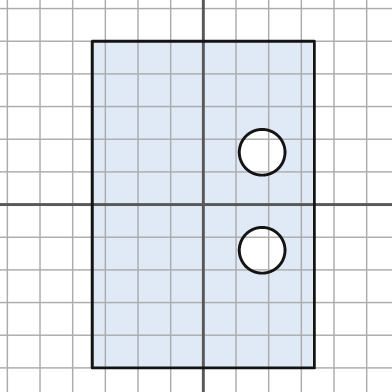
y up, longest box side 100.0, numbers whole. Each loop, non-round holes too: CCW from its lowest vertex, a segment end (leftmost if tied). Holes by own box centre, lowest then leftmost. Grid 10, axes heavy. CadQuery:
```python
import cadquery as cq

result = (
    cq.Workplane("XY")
    .moveTo(-34.0, -50.0)
    .lineTo(34.0, -50.0)
    .lineTo(34.0, 50.0)
    .lineTo(-34.0, 50.0)
    .close()
    .moveTo(18.0, -14.0)
    .circle(7.0)
    .moveTo(18.0, 16.0)
    .circle(7.0)
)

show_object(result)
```